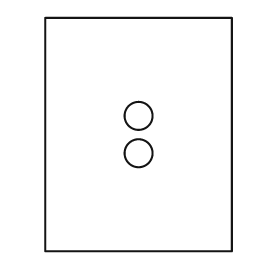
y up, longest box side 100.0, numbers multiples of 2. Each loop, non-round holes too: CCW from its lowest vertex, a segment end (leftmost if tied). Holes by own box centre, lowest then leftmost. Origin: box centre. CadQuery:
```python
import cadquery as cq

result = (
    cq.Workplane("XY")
    .moveTo(-40.0, -50.0)
    .lineTo(40.0, -50.0)
    .lineTo(40.0, 50.0)
    .lineTo(-40.0, 50.0)
    .close()
    .moveTo(0.0, -8.0)
    .circle(6.0)
    .moveTo(0.0, 8.0)
    .circle(6.0)
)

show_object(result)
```